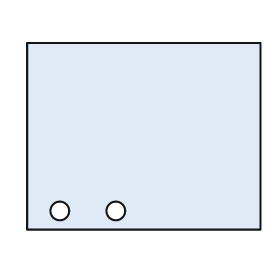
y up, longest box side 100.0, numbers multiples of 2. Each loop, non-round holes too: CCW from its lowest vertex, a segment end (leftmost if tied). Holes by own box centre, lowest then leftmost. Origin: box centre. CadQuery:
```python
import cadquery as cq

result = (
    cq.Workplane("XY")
    .moveTo(-50.0, -40.0)
    .lineTo(50.0, -40.0)
    .lineTo(50.0, 40.0)
    .lineTo(-50.0, 40.0)
    .close()
    .moveTo(-36.0, -32.0)
    .circle(4.0)
    .moveTo(-12.0, -32.0)
    .circle(4.0)
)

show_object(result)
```